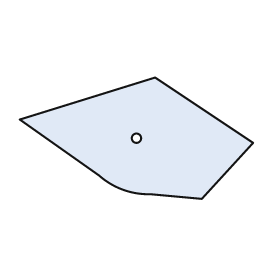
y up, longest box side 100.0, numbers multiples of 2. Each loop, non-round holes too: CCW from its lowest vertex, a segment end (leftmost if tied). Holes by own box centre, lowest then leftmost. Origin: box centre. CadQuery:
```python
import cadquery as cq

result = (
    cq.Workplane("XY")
    .moveTo(28.0, -26.0)
    .lineTo(50.0, -2.0)
    .lineTo(8.0, 26.0)
    .lineTo(-50.0, 8.0)
    .lineTo(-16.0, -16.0)
    .threePointArc((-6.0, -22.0), (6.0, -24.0))
    .close()
    .moveTo(0.0, 0.0)
    .circle(2.0)
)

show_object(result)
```